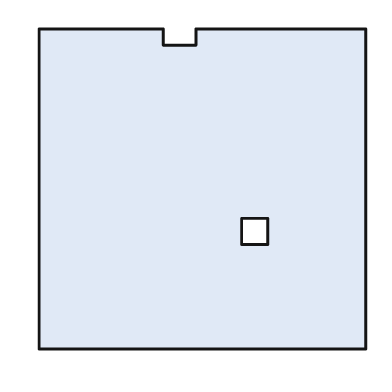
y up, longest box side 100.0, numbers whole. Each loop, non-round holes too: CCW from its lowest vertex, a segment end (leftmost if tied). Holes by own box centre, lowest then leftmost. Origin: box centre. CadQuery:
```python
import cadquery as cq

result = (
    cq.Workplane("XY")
    .moveTo(-50.0, -49.0)
    .lineTo(50.0, -49.0)
    .lineTo(50.0, 49.0)
    .lineTo(-2.0, 49.0)
    .lineTo(-2.0, 44.0)
    .lineTo(-12.0, 44.0)
    .lineTo(-12.0, 49.0)
    .lineTo(-50.0, 49.0)
    .close()
    .moveTo(12.0, -17.0)
    .lineTo(20.0, -17.0)
    .lineTo(20.0, -9.0)
    .lineTo(12.0, -9.0)
    .close()
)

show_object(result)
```